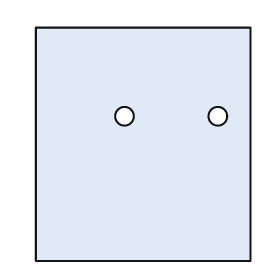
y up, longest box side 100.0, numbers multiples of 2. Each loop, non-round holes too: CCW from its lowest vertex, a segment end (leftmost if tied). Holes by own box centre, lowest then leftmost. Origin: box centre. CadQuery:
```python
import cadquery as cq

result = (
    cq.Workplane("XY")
    .moveTo(-46.0, -50.0)
    .lineTo(46.0, -50.0)
    .lineTo(46.0, 50.0)
    .lineTo(-46.0, 50.0)
    .close()
    .moveTo(-8.0, 12.0)
    .circle(4.0)
    .moveTo(32.0, 12.0)
    .circle(4.0)
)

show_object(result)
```